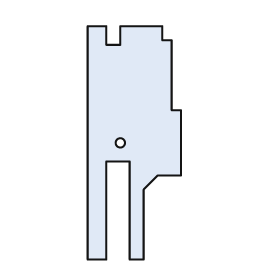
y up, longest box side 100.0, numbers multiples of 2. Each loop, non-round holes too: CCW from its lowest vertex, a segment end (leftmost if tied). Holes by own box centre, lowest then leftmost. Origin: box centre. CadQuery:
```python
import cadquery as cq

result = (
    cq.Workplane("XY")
    .moveTo(-20.0, -50.0)
    .lineTo(-12.0, -50.0)
    .lineTo(-12.0, -8.0)
    .lineTo(-2.0, -8.0)
    .lineTo(-2.0, -50.0)
    .lineTo(4.0, -50.0)
    .lineTo(4.0, -20.0)
    .lineTo(10.0, -14.0)
    .lineTo(20.0, -14.0)
    .lineTo(20.0, 14.0)
    .lineTo(16.0, 14.0)
    .lineTo(16.0, 44.0)
    .lineTo(12.0, 44.0)
    .lineTo(12.0, 50.0)
    .lineTo(-6.0, 50.0)
    .lineTo(-6.0, 42.0)
    .lineTo(-12.0, 42.0)
    .lineTo(-12.0, 50.0)
    .lineTo(-20.0, 50.0)
    .close()
    .moveTo(-6.0, 0.0)
    .circle(2.0)
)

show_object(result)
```